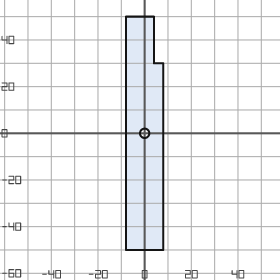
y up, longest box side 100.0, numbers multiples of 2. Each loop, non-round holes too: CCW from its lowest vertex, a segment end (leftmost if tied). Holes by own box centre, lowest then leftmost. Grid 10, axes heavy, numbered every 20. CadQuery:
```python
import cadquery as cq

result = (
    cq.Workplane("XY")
    .moveTo(-8.0, -50.0)
    .lineTo(8.0, -50.0)
    .lineTo(8.0, 30.0)
    .lineTo(4.0, 30.0)
    .lineTo(4.0, 50.0)
    .lineTo(-8.0, 50.0)
    .close()
    .moveTo(0.0, 0.0)
    .circle(2.0)
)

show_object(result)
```